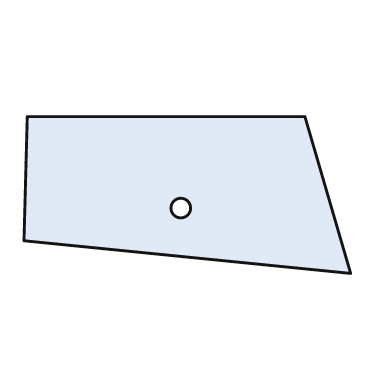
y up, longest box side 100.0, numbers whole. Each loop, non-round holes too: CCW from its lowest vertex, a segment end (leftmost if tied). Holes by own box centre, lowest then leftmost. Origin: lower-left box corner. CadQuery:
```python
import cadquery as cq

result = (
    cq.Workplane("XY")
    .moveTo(100.0, 0.0)
    .lineTo(86.0, 48.0)
    .lineTo(1.0, 48.0)
    .lineTo(0.0, 10.0)
    .close()
    .moveTo(48.0, 20.0)
    .circle(3.0)
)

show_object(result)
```